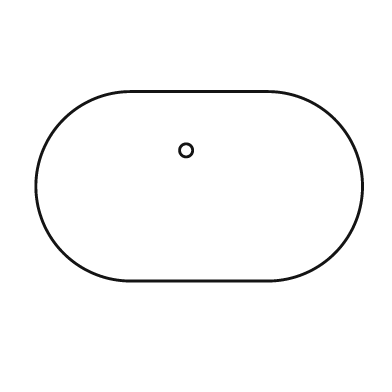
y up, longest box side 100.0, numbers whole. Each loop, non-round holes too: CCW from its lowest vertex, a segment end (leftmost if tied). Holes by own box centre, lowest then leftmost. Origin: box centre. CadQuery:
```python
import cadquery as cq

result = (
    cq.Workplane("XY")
    .moveTo(-21.0, -29.0)
    .lineTo(21.0, -29.0)
    .threePointArc((50.0, 0.0), (21.0, 29.0))
    .lineTo(-21.0, 29.0)
    .threePointArc((-50.0, 0.0), (-21.0, -29.0))
    .close()
    .moveTo(-4.0, 11.0)
    .circle(2.0)
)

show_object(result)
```